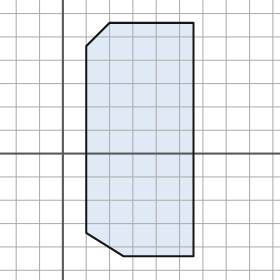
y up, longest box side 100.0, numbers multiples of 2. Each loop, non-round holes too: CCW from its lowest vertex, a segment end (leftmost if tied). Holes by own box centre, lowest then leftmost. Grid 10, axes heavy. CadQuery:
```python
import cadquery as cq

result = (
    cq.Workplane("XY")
    .moveTo(26.0, -44.0)
    .lineTo(56.0, -44.0)
    .lineTo(56.0, 56.0)
    .lineTo(20.0, 56.0)
    .lineTo(10.0, 46.0)
    .lineTo(10.0, -34.0)
    .close()
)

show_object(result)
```